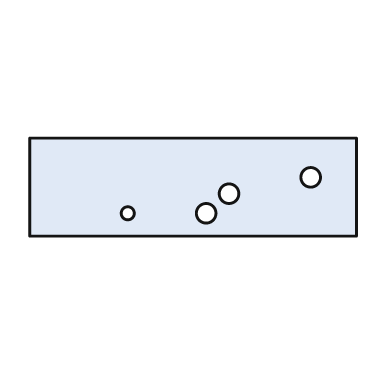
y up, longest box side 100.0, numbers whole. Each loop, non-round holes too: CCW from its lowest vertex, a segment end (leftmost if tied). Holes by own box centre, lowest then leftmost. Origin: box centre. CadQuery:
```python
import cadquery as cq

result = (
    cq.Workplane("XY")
    .moveTo(-50.0, -15.0)
    .lineTo(50.0, -15.0)
    .lineTo(50.0, 15.0)
    .lineTo(-50.0, 15.0)
    .close()
    .moveTo(-20.0, -8.0)
    .circle(2.0)
    .moveTo(4.0, -8.0)
    .circle(3.0)
    .moveTo(11.0, -2.0)
    .circle(3.0)
    .moveTo(36.0, 3.0)
    .circle(3.0)
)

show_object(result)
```